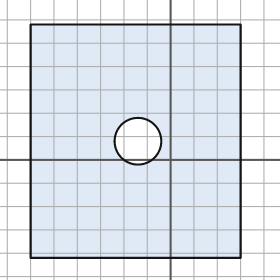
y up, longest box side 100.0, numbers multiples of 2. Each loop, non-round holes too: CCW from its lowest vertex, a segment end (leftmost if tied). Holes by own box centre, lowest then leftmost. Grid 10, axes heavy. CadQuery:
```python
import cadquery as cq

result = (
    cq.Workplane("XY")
    .moveTo(-60.0, -42.0)
    .lineTo(30.0, -42.0)
    .lineTo(30.0, 58.0)
    .lineTo(-60.0, 58.0)
    .close()
    .moveTo(-14.0, 8.0)
    .circle(10.0)
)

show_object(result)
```